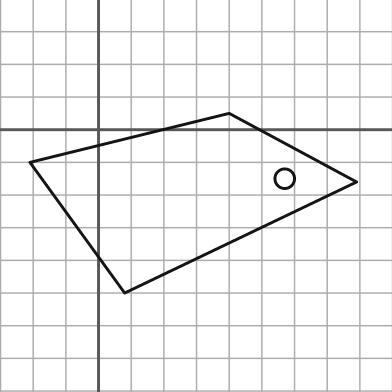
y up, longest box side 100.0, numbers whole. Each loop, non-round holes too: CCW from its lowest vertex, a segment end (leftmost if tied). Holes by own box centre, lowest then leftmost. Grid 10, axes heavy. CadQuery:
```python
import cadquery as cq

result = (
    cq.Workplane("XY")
    .moveTo(8.0, -50.0)
    .lineTo(79.0, -16.0)
    .lineTo(40.0, 5.0)
    .lineTo(-21.0, -10.0)
    .close()
    .moveTo(57.0, -15.0)
    .circle(3.0)
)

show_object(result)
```